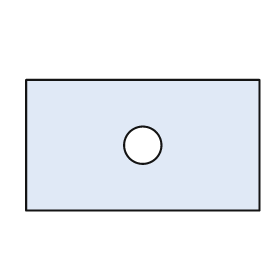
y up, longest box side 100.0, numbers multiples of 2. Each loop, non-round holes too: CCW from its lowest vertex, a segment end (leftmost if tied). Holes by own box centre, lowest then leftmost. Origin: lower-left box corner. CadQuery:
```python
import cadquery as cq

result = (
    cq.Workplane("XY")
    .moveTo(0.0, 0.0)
    .lineTo(100.0, 0.0)
    .lineTo(100.0, 56.0)
    .lineTo(0.0, 56.0)
    .close()
    .moveTo(50.0, 28.0)
    .circle(8.0)
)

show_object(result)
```